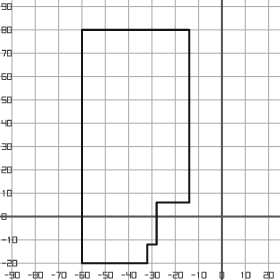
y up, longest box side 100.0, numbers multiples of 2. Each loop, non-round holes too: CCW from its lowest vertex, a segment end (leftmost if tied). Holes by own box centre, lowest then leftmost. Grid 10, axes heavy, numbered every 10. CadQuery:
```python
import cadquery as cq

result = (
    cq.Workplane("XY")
    .moveTo(-60.0, -20.0)
    .lineTo(-32.0, -20.0)
    .lineTo(-32.0, -12.0)
    .lineTo(-28.0, -12.0)
    .lineTo(-28.0, 6.0)
    .lineTo(-14.0, 6.0)
    .lineTo(-14.0, 80.0)
    .lineTo(-60.0, 80.0)
    .close()
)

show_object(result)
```